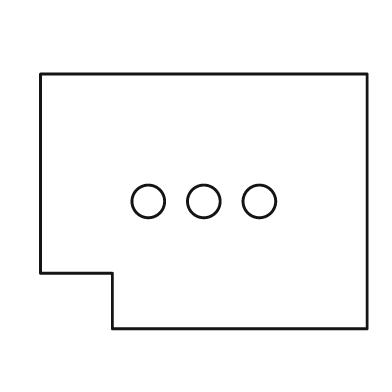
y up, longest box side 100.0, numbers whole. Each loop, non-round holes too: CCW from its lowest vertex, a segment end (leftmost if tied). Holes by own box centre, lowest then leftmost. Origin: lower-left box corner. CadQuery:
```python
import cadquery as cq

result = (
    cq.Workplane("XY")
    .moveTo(22.0, 0.0)
    .lineTo(100.0, 0.0)
    .lineTo(100.0, 78.0)
    .lineTo(0.0, 78.0)
    .lineTo(0.0, 17.0)
    .lineTo(22.0, 17.0)
    .close()
    .moveTo(33.0, 39.0)
    .circle(5.0)
    .moveTo(50.0, 39.0)
    .circle(5.0)
    .moveTo(67.0, 39.0)
    .circle(5.0)
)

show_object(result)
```